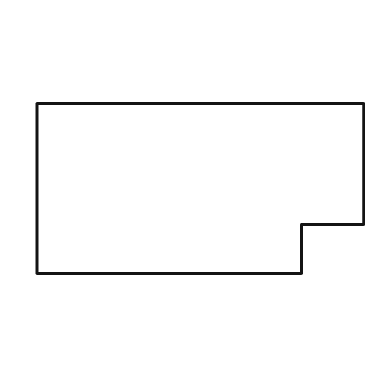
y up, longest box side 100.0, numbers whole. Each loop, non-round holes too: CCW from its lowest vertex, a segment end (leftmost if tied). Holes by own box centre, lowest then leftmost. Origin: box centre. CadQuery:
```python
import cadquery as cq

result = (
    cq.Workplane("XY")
    .moveTo(-50.0, -26.0)
    .lineTo(31.0, -26.0)
    .lineTo(31.0, -11.0)
    .lineTo(50.0, -11.0)
    .lineTo(50.0, 26.0)
    .lineTo(-50.0, 26.0)
    .close()
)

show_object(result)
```